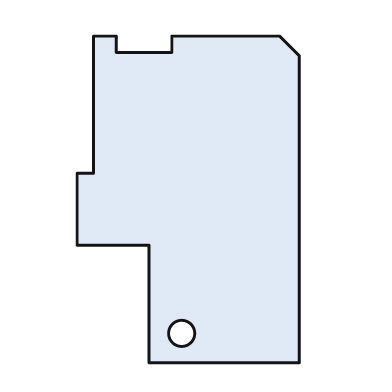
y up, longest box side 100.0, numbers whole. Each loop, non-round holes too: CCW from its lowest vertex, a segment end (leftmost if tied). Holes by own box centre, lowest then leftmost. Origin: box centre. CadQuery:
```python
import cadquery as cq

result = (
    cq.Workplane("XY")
    .moveTo(-12.0, -50.0)
    .lineTo(34.0, -50.0)
    .lineTo(34.0, 44.0)
    .lineTo(28.0, 50.0)
    .lineTo(-5.0, 50.0)
    .lineTo(-5.0, 45.0)
    .lineTo(-22.0, 45.0)
    .lineTo(-22.0, 50.0)
    .lineTo(-29.0, 50.0)
    .lineTo(-29.0, 8.0)
    .lineTo(-34.0, 8.0)
    .lineTo(-34.0, -14.0)
    .lineTo(-12.0, -14.0)
    .close()
    .moveTo(-2.0, -41.0)
    .circle(4.0)
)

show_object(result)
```